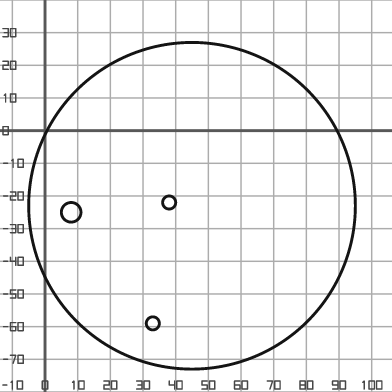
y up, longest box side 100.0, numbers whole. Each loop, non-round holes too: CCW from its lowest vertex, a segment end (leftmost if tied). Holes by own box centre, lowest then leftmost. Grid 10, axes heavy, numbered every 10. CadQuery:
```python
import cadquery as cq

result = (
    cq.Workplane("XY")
    .moveTo(45.0, -23.0)
    .circle(50.0)
    .moveTo(33.0, -59.0)
    .circle(2.0)
    .moveTo(8.0, -25.0)
    .circle(3.0)
    .moveTo(38.0, -22.0)
    .circle(2.0)
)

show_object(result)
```